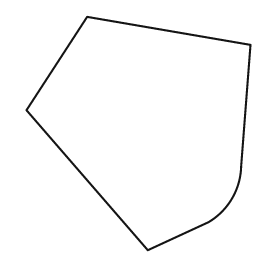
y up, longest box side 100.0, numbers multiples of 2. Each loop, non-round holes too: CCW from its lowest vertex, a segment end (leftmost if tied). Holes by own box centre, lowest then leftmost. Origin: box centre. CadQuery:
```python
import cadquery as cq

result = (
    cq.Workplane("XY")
    .moveTo(4.0, -50.0)
    .lineTo(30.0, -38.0)
    .threePointArc((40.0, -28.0), (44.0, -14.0))
    .lineTo(48.0, 38.0)
    .lineTo(-22.0, 50.0)
    .lineTo(-48.0, 10.0)
    .close()
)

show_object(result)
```